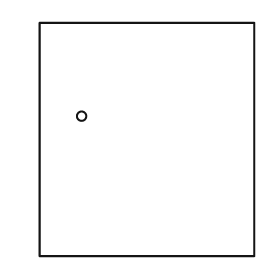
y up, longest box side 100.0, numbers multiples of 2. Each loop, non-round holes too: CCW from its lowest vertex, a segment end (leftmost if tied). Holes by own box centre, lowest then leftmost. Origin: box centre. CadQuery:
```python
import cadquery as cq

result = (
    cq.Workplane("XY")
    .moveTo(-46.0, -50.0)
    .lineTo(46.0, -50.0)
    .lineTo(46.0, 50.0)
    .lineTo(-46.0, 50.0)
    .close()
    .moveTo(-28.0, 10.0)
    .circle(2.0)
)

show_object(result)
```